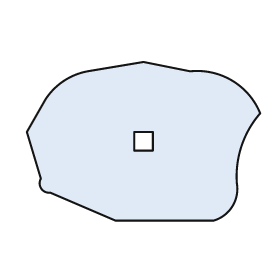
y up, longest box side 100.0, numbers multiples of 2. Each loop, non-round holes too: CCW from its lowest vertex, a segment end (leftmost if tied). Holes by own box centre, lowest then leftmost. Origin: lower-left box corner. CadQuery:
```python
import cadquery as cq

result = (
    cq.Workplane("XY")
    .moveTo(38.0, 0.0)
    .lineTo(80.0, 0.0)
    .threePointArc((88.0, 6.0), (90.0, 16.0))
    .threePointArc((92.0, 32.0), (100.0, 46.0))
    .threePointArc((88.0, 60.0), (70.0, 64.0))
    .lineTo(50.0, 68.0)
    .lineTo(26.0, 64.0)
    .threePointArc((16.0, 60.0), (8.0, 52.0))
    .lineTo(0.0, 38.0)
    .lineTo(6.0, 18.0)
    .threePointArc((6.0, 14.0), (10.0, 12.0))
    .close()
    .moveTo(46.0, 30.0)
    .lineTo(54.0, 30.0)
    .lineTo(54.0, 38.0)
    .lineTo(46.0, 38.0)
    .close()
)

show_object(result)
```